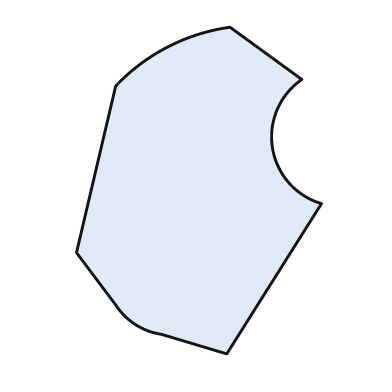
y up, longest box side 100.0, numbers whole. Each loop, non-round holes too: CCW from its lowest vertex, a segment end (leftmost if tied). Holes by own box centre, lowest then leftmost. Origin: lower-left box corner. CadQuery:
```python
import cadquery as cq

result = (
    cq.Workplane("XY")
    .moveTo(46.0, 0.0)
    .lineTo(75.0, 46.0)
    .threePointArc((60.0, 63.0), (69.0, 84.0))
    .lineTo(47.0, 100.0)
    .threePointArc((28.0, 94.0), (12.0, 82.0))
    .lineTo(0.0, 31.0)
    .lineTo(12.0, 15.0)
    .threePointArc((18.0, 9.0), (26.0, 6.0))
    .close()
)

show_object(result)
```